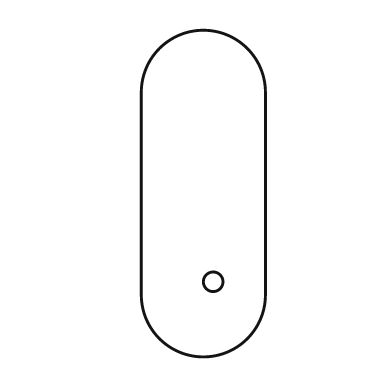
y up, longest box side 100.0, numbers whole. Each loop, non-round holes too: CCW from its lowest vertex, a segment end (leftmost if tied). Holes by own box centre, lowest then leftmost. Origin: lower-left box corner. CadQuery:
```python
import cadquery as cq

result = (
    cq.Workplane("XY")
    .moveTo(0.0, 19.0)
    .threePointArc((19.0, 0.0), (38.0, 19.0))
    .lineTo(38.0, 81.0)
    .threePointArc((19.0, 100.0), (0.0, 81.0))
    .close()
    .moveTo(22.0, 23.0)
    .circle(3.0)
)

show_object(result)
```